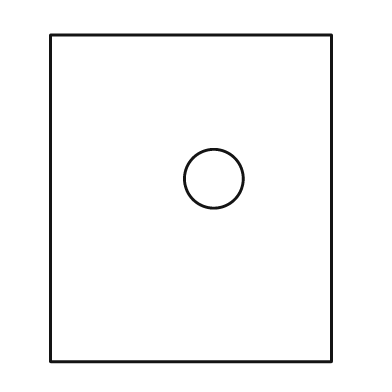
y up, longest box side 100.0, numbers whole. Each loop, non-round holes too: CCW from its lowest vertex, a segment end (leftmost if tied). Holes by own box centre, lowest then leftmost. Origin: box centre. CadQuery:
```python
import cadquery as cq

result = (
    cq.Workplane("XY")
    .moveTo(-43.0, -50.0)
    .lineTo(43.0, -50.0)
    .lineTo(43.0, 50.0)
    .lineTo(-43.0, 50.0)
    .close()
    .moveTo(7.0, 6.0)
    .circle(9.0)
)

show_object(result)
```